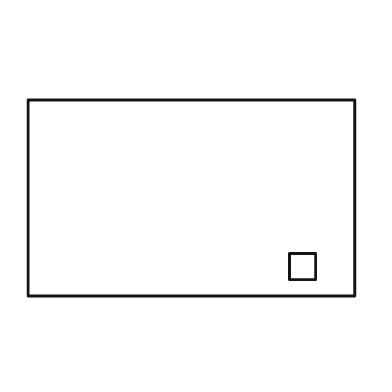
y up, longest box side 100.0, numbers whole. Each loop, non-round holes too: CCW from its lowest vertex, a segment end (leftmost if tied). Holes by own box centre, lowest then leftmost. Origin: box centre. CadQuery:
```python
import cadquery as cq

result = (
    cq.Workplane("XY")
    .moveTo(-50.0, -30.0)
    .lineTo(50.0, -30.0)
    .lineTo(50.0, 30.0)
    .lineTo(-50.0, 30.0)
    .close()
    .moveTo(30.0, -25.0)
    .lineTo(38.0, -25.0)
    .lineTo(38.0, -17.0)
    .lineTo(30.0, -17.0)
    .close()
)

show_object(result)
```